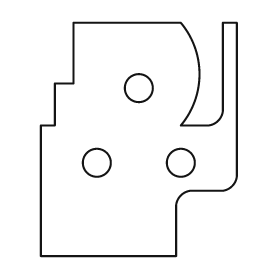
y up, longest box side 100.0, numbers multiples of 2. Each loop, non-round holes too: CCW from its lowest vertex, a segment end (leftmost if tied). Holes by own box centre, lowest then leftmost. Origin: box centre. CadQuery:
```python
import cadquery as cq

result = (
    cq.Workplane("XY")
    .moveTo(-42.0, -50.0)
    .lineTo(16.0, -50.0)
    .lineTo(16.0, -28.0)
    .threePointArc((18.0, -24.0), (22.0, -22.0))
    .lineTo(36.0, -22.0)
    .threePointArc((40.0, -20.0), (42.0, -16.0))
    .lineTo(42.0, 50.0)
    .lineTo(36.0, 50.0)
    .lineTo(36.0, 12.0)
    .threePointArc((34.0, 8.0), (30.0, 6.0))
    .lineTo(18.0, 6.0)
    .threePointArc((26.0, 28.0), (18.0, 50.0))
    .lineTo(-28.0, 50.0)
    .lineTo(-28.0, 24.0)
    .lineTo(-36.0, 24.0)
    .lineTo(-36.0, 6.0)
    .lineTo(-42.0, 6.0)
    .close()
    .moveTo(-18.0, -10.0)
    .circle(6.0)
    .moveTo(18.0, -10.0)
    .circle(6.0)
    .moveTo(0.0, 22.0)
    .circle(6.0)
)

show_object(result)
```